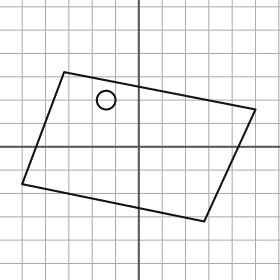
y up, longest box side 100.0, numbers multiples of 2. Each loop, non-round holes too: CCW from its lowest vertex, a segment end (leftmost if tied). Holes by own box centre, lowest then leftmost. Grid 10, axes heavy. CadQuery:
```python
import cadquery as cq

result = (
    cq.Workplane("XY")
    .moveTo(28.0, -32.0)
    .lineTo(50.0, 16.0)
    .lineTo(-32.0, 32.0)
    .lineTo(-50.0, -16.0)
    .close()
    .moveTo(-14.0, 20.0)
    .circle(4.0)
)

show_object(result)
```